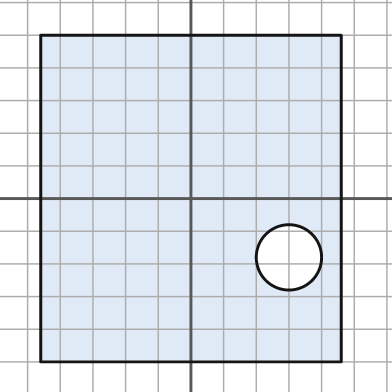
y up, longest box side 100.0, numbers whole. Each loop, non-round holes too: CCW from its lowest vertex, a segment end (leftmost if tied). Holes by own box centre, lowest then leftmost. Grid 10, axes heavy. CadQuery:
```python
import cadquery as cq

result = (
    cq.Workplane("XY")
    .moveTo(-46.0, -50.0)
    .lineTo(46.0, -50.0)
    .lineTo(46.0, 50.0)
    .lineTo(-46.0, 50.0)
    .close()
    .moveTo(30.0, -18.0)
    .circle(10.0)
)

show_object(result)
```